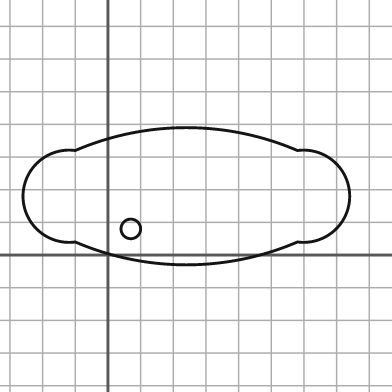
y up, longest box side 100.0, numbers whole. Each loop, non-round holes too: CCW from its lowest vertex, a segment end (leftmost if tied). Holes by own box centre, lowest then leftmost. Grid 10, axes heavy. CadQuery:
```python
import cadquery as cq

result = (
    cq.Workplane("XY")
    .moveTo(-10.0, 4.0)
    .threePointArc((24.0, -3.0), (58.0, 4.0))
    .threePointArc((74.0, 18.0), (58.0, 32.0))
    .threePointArc((24.0, 39.0), (-10.0, 32.0))
    .threePointArc((-26.0, 18.0), (-10.0, 4.0))
    .close()
    .moveTo(7.0, 8.0)
    .circle(3.0)
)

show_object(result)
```